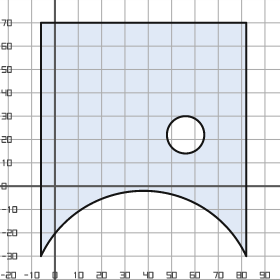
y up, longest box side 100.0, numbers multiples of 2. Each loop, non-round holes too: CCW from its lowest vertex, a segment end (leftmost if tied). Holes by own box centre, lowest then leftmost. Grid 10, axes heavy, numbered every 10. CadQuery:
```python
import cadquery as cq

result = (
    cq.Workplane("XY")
    .moveTo(-6.0, -30.0)
    .threePointArc((38.0, -2.0), (82.0, -30.0))
    .lineTo(82.0, 70.0)
    .lineTo(-6.0, 70.0)
    .close()
    .moveTo(56.0, 22.0)
    .circle(8.0)
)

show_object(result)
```